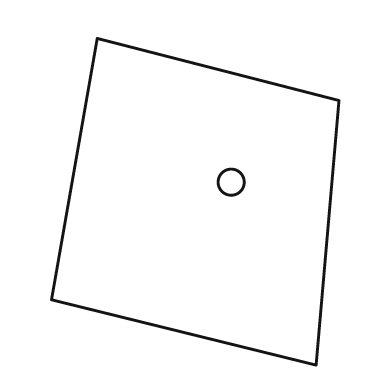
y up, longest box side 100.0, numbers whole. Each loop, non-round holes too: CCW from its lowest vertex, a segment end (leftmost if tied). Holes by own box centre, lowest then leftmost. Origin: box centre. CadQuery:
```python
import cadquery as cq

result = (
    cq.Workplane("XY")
    .moveTo(37.0, -50.0)
    .lineTo(44.0, 31.0)
    .lineTo(-30.0, 50.0)
    .lineTo(-44.0, -30.0)
    .close()
    .moveTo(11.0, 6.0)
    .circle(4.0)
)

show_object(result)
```